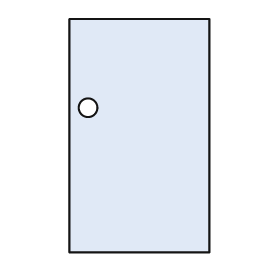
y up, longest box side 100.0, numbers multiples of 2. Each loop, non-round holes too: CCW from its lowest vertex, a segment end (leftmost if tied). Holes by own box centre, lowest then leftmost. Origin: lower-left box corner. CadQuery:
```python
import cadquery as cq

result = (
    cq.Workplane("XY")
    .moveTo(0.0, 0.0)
    .lineTo(60.0, 0.0)
    .lineTo(60.0, 100.0)
    .lineTo(0.0, 100.0)
    .close()
    .moveTo(8.0, 62.0)
    .circle(4.0)
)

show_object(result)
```